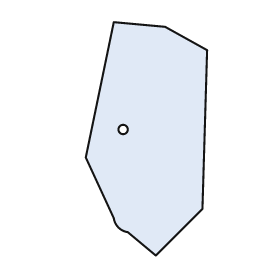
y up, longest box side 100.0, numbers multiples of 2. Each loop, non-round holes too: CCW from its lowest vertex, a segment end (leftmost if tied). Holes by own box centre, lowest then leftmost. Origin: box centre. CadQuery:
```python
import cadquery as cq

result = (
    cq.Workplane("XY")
    .moveTo(4.0, -50.0)
    .lineTo(24.0, -30.0)
    .lineTo(26.0, 38.0)
    .lineTo(8.0, 48.0)
    .lineTo(-14.0, 50.0)
    .lineTo(-26.0, -8.0)
    .lineTo(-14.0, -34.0)
    .threePointArc((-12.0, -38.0), (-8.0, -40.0))
    .close()
    .moveTo(-10.0, 4.0)
    .circle(2.0)
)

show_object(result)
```